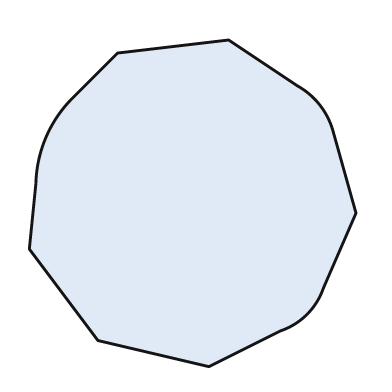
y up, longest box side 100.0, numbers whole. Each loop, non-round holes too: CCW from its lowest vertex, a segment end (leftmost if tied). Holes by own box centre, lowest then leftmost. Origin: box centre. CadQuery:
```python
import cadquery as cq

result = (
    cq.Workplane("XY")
    .moveTo(5.0, -50.0)
    .lineTo(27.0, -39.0)
    .threePointArc((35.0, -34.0), (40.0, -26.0))
    .lineTo(50.0, -3.0)
    .lineTo(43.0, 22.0)
    .threePointArc((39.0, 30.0), (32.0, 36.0))
    .lineTo(11.0, 50.0)
    .lineTo(-23.0, 46.0)
    .lineTo(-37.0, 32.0)
    .threePointArc((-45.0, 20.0), (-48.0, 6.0))
    .lineTo(-50.0, -14.0)
    .lineTo(-29.0, -42.0)
    .close()
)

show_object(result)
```